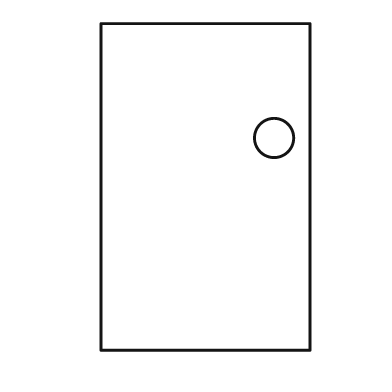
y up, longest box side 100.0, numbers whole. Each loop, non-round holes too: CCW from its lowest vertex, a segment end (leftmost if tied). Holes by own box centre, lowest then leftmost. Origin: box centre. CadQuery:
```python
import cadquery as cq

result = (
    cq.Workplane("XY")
    .moveTo(-32.0, -50.0)
    .lineTo(32.0, -50.0)
    .lineTo(32.0, 50.0)
    .lineTo(-32.0, 50.0)
    .close()
    .moveTo(21.0, 15.0)
    .circle(6.0)
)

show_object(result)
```